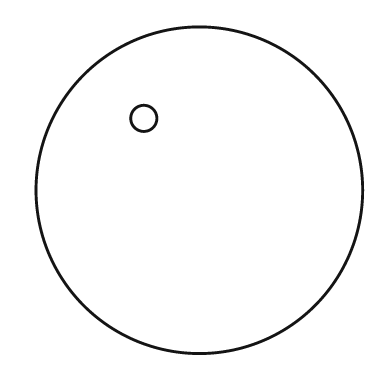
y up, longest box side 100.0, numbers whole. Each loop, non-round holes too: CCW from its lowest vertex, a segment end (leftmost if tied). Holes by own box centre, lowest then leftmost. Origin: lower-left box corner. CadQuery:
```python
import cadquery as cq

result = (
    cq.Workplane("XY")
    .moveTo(50.0, 50.0)
    .circle(50.0)
    .moveTo(33.0, 72.0)
    .circle(4.0)
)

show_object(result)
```